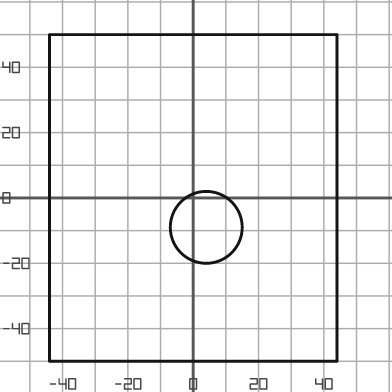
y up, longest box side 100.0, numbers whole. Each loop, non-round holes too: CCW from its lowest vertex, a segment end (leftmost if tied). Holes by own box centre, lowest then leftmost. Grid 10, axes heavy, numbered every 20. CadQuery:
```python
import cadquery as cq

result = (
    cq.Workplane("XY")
    .moveTo(-44.0, -50.0)
    .lineTo(44.0, -50.0)
    .lineTo(44.0, 50.0)
    .lineTo(-44.0, 50.0)
    .close()
    .moveTo(4.0, -9.0)
    .circle(11.0)
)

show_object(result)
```